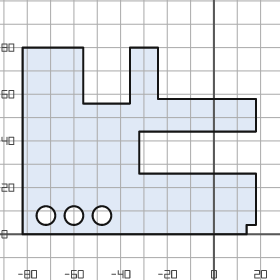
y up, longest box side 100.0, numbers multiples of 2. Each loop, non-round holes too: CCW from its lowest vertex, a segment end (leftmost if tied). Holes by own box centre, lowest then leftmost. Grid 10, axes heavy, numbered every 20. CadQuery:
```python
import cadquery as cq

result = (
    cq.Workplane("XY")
    .moveTo(-82.0, 0.0)
    .lineTo(14.0, 0.0)
    .lineTo(14.0, 4.0)
    .lineTo(18.0, 4.0)
    .lineTo(18.0, 26.0)
    .lineTo(-32.0, 26.0)
    .lineTo(-32.0, 44.0)
    .lineTo(18.0, 44.0)
    .lineTo(18.0, 58.0)
    .lineTo(-24.0, 58.0)
    .lineTo(-24.0, 80.0)
    .lineTo(-36.0, 80.0)
    .lineTo(-36.0, 56.0)
    .lineTo(-56.0, 56.0)
    .lineTo(-56.0, 80.0)
    .lineTo(-82.0, 80.0)
    .close()
    .moveTo(-72.0, 8.0)
    .circle(4.0)
    .moveTo(-60.0, 8.0)
    .circle(4.0)
    .moveTo(-48.0, 8.0)
    .circle(4.0)
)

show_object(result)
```